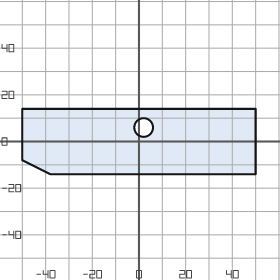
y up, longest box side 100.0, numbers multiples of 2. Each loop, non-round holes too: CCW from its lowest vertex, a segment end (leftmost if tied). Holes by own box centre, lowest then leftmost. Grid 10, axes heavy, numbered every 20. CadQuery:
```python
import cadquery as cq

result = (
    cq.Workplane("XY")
    .moveTo(-38.0, -14.0)
    .lineTo(50.0, -14.0)
    .lineTo(50.0, 14.0)
    .lineTo(-50.0, 14.0)
    .lineTo(-50.0, -8.0)
    .close()
    .moveTo(2.0, 6.0)
    .circle(4.0)
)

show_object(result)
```